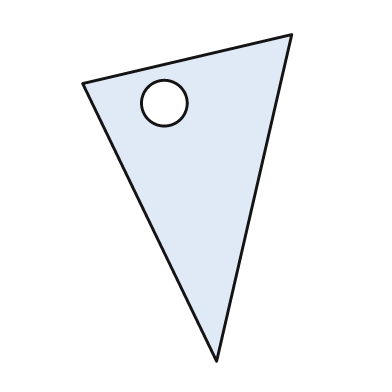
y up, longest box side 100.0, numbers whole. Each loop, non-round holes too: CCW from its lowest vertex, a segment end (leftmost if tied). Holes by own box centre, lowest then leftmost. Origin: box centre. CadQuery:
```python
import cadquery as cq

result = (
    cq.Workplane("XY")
    .moveTo(9.0, -50.0)
    .lineTo(32.0, 50.0)
    .lineTo(-32.0, 35.0)
    .close()
    .moveTo(-7.0, 29.0)
    .circle(7.0)
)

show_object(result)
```